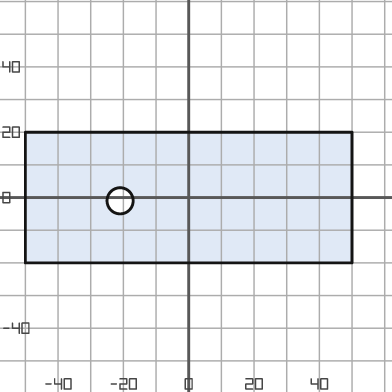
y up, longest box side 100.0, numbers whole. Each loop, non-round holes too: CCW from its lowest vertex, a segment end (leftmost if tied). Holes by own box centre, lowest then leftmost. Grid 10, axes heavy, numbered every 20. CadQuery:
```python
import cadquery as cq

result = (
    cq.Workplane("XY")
    .moveTo(-50.0, -20.0)
    .lineTo(50.0, -20.0)
    .lineTo(50.0, 20.0)
    .lineTo(-50.0, 20.0)
    .close()
    .moveTo(-21.0, -1.0)
    .circle(4.0)
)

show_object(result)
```